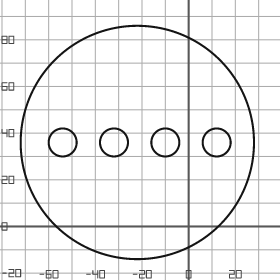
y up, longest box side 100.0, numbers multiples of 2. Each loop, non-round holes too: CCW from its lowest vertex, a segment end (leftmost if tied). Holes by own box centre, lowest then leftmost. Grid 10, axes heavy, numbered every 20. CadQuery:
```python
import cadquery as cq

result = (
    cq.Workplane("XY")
    .moveTo(-22.0, 36.0)
    .circle(50.0)
    .moveTo(-54.0, 36.0)
    .circle(6.0)
    .moveTo(-32.0, 36.0)
    .circle(6.0)
    .moveTo(-10.0, 36.0)
    .circle(6.0)
    .moveTo(12.0, 36.0)
    .circle(6.0)
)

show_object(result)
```